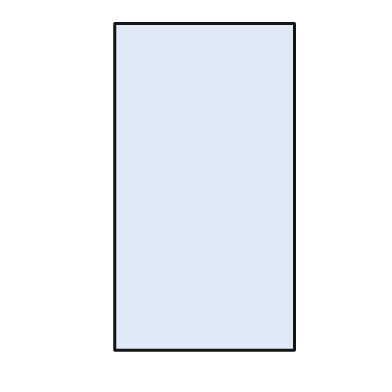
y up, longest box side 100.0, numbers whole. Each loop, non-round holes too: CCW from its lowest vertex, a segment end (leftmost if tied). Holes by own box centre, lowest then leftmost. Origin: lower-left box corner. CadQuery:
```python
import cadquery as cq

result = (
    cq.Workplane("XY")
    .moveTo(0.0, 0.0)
    .lineTo(55.0, 0.0)
    .lineTo(55.0, 100.0)
    .lineTo(0.0, 100.0)
    .close()
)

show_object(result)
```